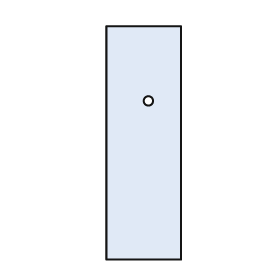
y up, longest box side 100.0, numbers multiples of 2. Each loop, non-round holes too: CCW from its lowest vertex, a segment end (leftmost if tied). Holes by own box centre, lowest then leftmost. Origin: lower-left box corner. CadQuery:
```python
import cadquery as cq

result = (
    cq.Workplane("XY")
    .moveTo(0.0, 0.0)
    .lineTo(32.0, 0.0)
    .lineTo(32.0, 100.0)
    .lineTo(0.0, 100.0)
    .close()
    .moveTo(18.0, 68.0)
    .circle(2.0)
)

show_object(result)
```